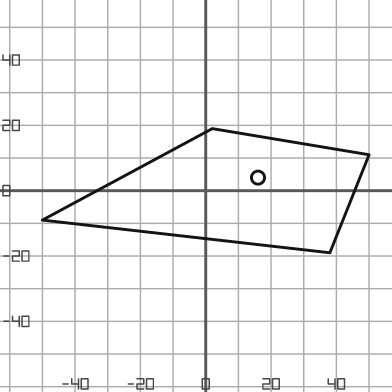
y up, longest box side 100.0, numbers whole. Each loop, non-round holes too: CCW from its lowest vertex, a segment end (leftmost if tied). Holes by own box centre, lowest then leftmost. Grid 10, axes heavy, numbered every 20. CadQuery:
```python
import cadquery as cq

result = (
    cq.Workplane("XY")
    .moveTo(38.0, -19.0)
    .lineTo(50.0, 11.0)
    .lineTo(2.0, 19.0)
    .lineTo(-50.0, -9.0)
    .close()
    .moveTo(16.0, 4.0)
    .circle(2.0)
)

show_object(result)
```